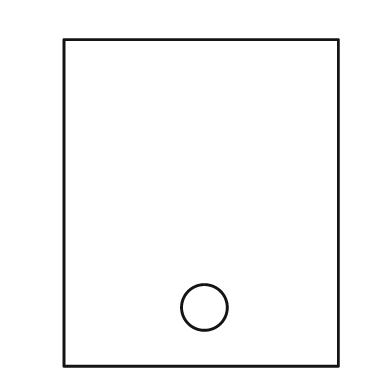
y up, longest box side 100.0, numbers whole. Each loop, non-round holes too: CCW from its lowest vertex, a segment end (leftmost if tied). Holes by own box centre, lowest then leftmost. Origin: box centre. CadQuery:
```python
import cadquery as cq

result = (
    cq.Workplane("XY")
    .moveTo(-42.0, -50.0)
    .lineTo(42.0, -50.0)
    .lineTo(42.0, 50.0)
    .lineTo(-42.0, 50.0)
    .close()
    .moveTo(1.0, -32.0)
    .circle(7.0)
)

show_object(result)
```